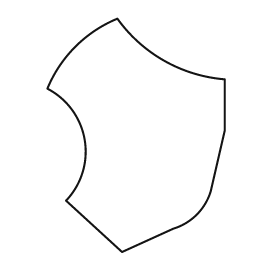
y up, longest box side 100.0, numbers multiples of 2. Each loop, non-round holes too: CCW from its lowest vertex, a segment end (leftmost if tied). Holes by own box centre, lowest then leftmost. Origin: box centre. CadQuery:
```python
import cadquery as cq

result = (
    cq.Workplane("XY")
    .moveTo(-6.0, -50.0)
    .lineTo(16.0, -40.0)
    .threePointArc((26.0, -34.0), (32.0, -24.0))
    .lineTo(38.0, 2.0)
    .lineTo(38.0, 24.0)
    .threePointArc((12.0, 32.0), (-8.0, 50.0))
    .threePointArc((-26.0, 38.0), (-38.0, 20.0))
    .threePointArc((-22.0, -2.0), (-30.0, -28.0))
    .close()
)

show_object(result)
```